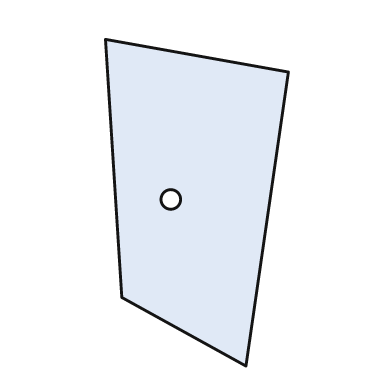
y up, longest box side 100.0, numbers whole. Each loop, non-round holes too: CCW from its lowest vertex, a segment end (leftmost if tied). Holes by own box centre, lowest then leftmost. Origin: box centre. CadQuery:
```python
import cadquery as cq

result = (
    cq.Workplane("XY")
    .moveTo(15.0, -50.0)
    .lineTo(28.0, 40.0)
    .lineTo(-28.0, 50.0)
    .lineTo(-23.0, -29.0)
    .close()
    .moveTo(-8.0, 1.0)
    .circle(3.0)
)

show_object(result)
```